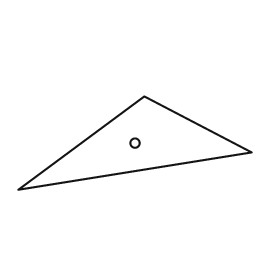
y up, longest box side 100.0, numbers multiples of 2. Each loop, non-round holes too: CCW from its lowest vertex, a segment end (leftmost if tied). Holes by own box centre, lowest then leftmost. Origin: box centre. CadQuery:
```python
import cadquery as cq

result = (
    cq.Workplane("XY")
    .moveTo(-50.0, -20.0)
    .lineTo(50.0, -4.0)
    .lineTo(4.0, 20.0)
    .close()
    .moveTo(0.0, 0.0)
    .circle(2.0)
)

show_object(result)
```